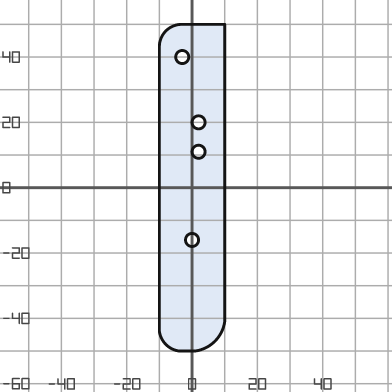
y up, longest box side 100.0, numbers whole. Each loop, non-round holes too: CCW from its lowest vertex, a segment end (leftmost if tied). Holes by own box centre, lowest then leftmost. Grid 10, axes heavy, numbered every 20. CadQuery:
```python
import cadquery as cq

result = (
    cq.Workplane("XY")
    .moveTo(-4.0, -50.0)
    .lineTo(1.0, -50.0)
    .threePointArc((7.0, -47.0), (10.0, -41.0))
    .lineTo(10.0, 50.0)
    .lineTo(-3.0, 50.0)
    .threePointArc((-8.0, 48.0), (-10.0, 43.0))
    .lineTo(-10.0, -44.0)
    .threePointArc((-8.0, -48.0), (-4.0, -50.0))
    .close()
    .moveTo(0.0, -16.0)
    .circle(2.0)
    .moveTo(2.0, 11.0)
    .circle(2.0)
    .moveTo(2.0, 20.0)
    .circle(2.0)
    .moveTo(-3.0, 40.0)
    .circle(2.0)
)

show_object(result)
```